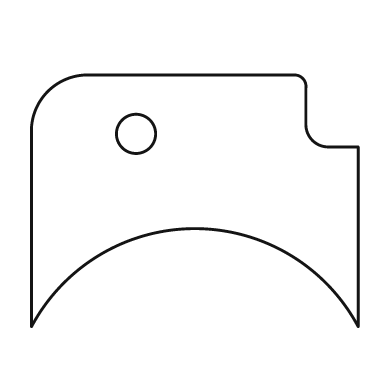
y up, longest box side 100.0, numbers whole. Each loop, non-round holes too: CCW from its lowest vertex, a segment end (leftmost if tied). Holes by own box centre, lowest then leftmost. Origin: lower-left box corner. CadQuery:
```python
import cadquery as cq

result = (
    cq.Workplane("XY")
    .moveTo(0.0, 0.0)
    .threePointArc((50.0, 30.0), (100.0, 0.0))
    .lineTo(100.0, 55.0)
    .lineTo(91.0, 55.0)
    .threePointArc((86.0, 57.0), (84.0, 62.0))
    .lineTo(84.0, 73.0)
    .threePointArc((83.0, 76.0), (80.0, 77.0))
    .lineTo(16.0, 77.0)
    .threePointArc((5.0, 72.0), (0.0, 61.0))
    .close()
    .moveTo(32.0, 59.0)
    .circle(6.0)
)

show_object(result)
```